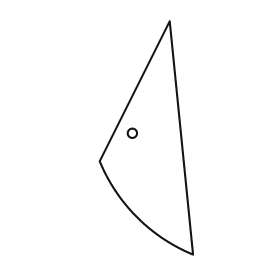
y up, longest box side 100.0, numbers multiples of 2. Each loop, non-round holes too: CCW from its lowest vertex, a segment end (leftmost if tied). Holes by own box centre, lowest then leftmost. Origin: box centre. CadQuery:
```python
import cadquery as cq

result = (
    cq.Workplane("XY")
    .moveTo(20.0, -50.0)
    .lineTo(10.0, 50.0)
    .lineTo(-20.0, -10.0)
    .threePointArc((-4.0, -34.0), (20.0, -50.0))
    .close()
    .moveTo(-6.0, 2.0)
    .circle(2.0)
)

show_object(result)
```